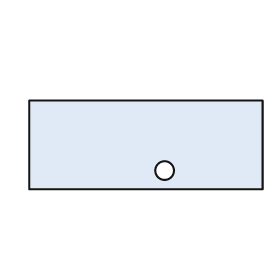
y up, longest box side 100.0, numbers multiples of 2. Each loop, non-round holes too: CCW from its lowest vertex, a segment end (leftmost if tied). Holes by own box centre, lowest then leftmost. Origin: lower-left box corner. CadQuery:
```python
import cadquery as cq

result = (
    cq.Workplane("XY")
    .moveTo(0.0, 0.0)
    .lineTo(100.0, 0.0)
    .lineTo(100.0, 38.0)
    .lineTo(0.0, 38.0)
    .close()
    .moveTo(58.0, 8.0)
    .circle(4.0)
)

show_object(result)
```